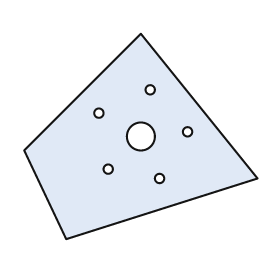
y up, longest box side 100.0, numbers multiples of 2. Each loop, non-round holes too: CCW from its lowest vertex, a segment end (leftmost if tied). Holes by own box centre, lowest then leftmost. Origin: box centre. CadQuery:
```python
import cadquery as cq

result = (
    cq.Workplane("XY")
    .moveTo(-32.0, -44.0)
    .lineTo(50.0, -18.0)
    .lineTo(0.0, 44.0)
    .lineTo(-50.0, -6.0)
    .close()
    .moveTo(8.0, -18.0)
    .circle(2.0)
    .moveTo(-14.0, -14.0)
    .circle(2.0)
    .moveTo(0.0, 0.0)
    .circle(6.0)
    .moveTo(20.0, 2.0)
    .circle(2.0)
    .moveTo(-18.0, 10.0)
    .circle(2.0)
    .moveTo(4.0, 20.0)
    .circle(2.0)
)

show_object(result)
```